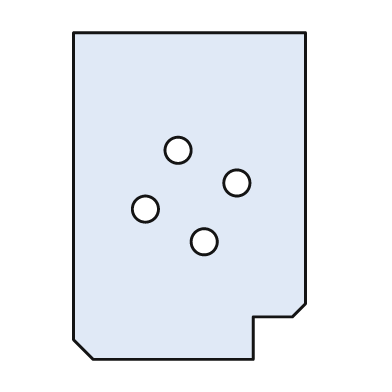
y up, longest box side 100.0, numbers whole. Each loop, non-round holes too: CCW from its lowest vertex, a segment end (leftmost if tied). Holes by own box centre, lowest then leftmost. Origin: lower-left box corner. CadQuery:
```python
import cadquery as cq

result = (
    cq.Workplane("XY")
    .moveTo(6.0, 0.0)
    .lineTo(55.0, 0.0)
    .lineTo(55.0, 13.0)
    .lineTo(67.0, 13.0)
    .lineTo(71.0, 17.0)
    .lineTo(71.0, 100.0)
    .lineTo(0.0, 100.0)
    .lineTo(0.0, 6.0)
    .close()
    .moveTo(40.0, 36.0)
    .circle(4.0)
    .moveTo(22.0, 46.0)
    .circle(4.0)
    .moveTo(50.0, 54.0)
    .circle(4.0)
    .moveTo(32.0, 64.0)
    .circle(4.0)
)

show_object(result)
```